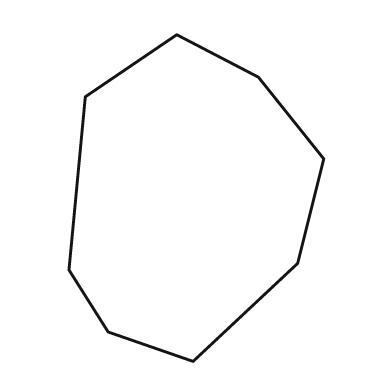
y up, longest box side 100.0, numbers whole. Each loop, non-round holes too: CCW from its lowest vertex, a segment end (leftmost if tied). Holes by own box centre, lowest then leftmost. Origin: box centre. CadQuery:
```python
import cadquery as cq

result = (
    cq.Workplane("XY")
    .moveTo(-1.0, -50.0)
    .lineTo(31.0, -20.0)
    .lineTo(39.0, 12.0)
    .lineTo(19.0, 37.0)
    .lineTo(-6.0, 50.0)
    .lineTo(-34.0, 31.0)
    .lineTo(-39.0, -22.0)
    .lineTo(-27.0, -41.0)
    .close()
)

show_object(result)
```